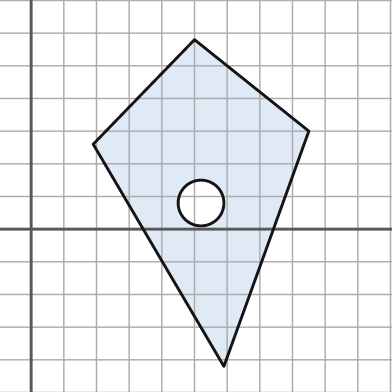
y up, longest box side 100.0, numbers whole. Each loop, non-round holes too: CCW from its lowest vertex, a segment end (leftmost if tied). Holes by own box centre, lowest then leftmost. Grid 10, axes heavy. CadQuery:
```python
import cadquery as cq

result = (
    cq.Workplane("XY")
    .moveTo(59.0, -42.0)
    .lineTo(85.0, 30.0)
    .lineTo(50.0, 58.0)
    .lineTo(19.0, 26.0)
    .close()
    .moveTo(52.0, 8.0)
    .circle(7.0)
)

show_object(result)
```